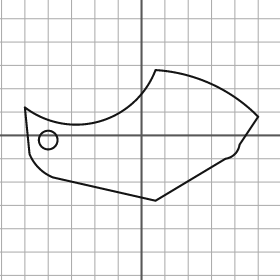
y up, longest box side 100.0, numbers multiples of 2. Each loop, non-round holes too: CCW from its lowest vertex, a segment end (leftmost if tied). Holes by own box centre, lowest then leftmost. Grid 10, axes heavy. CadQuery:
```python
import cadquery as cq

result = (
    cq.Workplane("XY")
    .moveTo(6.0, -28.0)
    .lineTo(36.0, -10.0)
    .threePointArc((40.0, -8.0), (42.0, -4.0))
    .lineTo(50.0, 8.0)
    .threePointArc((30.0, 22.0), (6.0, 28.0))
    .threePointArc((-18.0, 6.0), (-50.0, 12.0))
    .lineTo(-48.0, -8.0)
    .threePointArc((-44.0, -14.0), (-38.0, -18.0))
    .close()
    .moveTo(-40.0, -2.0)
    .circle(4.0)
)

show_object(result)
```